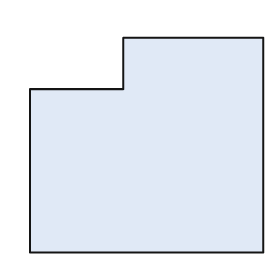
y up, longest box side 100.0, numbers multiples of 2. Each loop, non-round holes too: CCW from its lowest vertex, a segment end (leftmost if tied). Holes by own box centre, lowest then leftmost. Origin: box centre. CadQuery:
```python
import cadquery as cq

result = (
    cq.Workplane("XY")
    .moveTo(-50.0, -46.0)
    .lineTo(50.0, -46.0)
    .lineTo(50.0, 46.0)
    .lineTo(-10.0, 46.0)
    .lineTo(-10.0, 24.0)
    .lineTo(-50.0, 24.0)
    .close()
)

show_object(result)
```